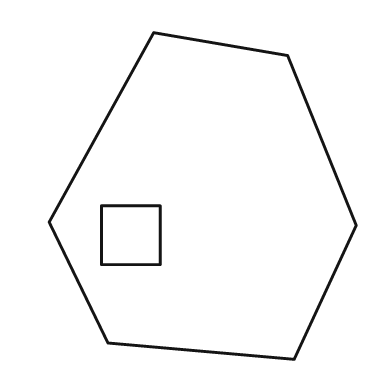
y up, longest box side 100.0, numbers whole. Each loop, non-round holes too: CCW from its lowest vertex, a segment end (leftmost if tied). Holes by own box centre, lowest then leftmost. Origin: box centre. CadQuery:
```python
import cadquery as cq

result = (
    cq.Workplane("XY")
    .moveTo(28.0, -50.0)
    .lineTo(47.0, -9.0)
    .lineTo(26.0, 43.0)
    .lineTo(-15.0, 50.0)
    .lineTo(-47.0, -8.0)
    .lineTo(-29.0, -45.0)
    .close()
    .moveTo(-31.0, -21.0)
    .lineTo(-13.0, -21.0)
    .lineTo(-13.0, -3.0)
    .lineTo(-31.0, -3.0)
    .close()
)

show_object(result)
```